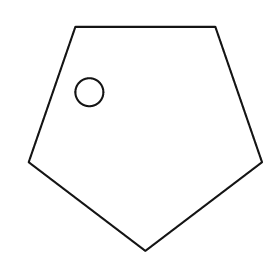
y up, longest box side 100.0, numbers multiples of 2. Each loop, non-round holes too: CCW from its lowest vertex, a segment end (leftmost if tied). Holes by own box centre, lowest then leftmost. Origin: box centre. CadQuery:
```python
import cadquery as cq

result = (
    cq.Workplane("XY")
    .moveTo(0.0, -48.0)
    .lineTo(50.0, -10.0)
    .lineTo(30.0, 48.0)
    .lineTo(-30.0, 48.0)
    .lineTo(-50.0, -10.0)
    .close()
    .moveTo(-24.0, 20.0)
    .circle(6.0)
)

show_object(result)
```